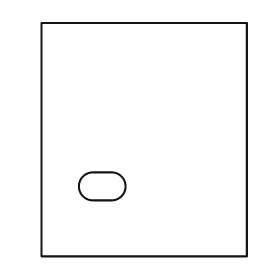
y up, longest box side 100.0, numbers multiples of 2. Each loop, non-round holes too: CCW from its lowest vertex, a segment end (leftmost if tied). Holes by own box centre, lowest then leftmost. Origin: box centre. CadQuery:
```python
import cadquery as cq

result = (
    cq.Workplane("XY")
    .moveTo(-44.0, -50.0)
    .lineTo(44.0, -50.0)
    .lineTo(44.0, 50.0)
    .lineTo(-44.0, 50.0)
    .close()
    .moveTo(-22.0, -26.0)
    .lineTo(-14.0, -26.0)
    .threePointArc((-8.0, -20.0), (-14.0, -14.0))
    .lineTo(-22.0, -14.0)
    .threePointArc((-28.0, -20.0), (-22.0, -26.0))
    .close()
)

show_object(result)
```